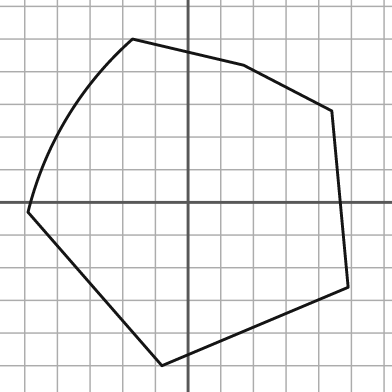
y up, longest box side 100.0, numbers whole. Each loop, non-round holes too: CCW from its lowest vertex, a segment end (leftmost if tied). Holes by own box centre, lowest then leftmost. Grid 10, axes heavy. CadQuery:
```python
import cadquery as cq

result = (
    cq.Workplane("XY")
    .moveTo(-8.0, -50.0)
    .lineTo(49.0, -26.0)
    .lineTo(44.0, 28.0)
    .lineTo(17.0, 42.0)
    .lineTo(-17.0, 50.0)
    .threePointArc((-37.0, 26.0), (-49.0, -3.0))
    .close()
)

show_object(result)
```